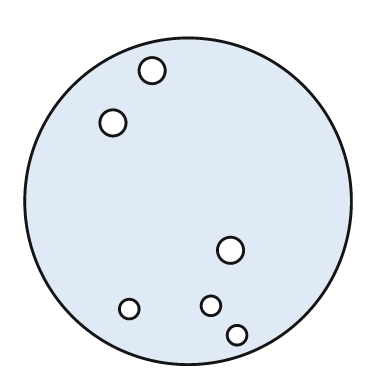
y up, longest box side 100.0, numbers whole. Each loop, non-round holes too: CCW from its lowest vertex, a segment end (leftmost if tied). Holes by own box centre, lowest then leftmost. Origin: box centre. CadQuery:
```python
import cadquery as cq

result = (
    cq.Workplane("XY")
    .moveTo(0.0, 0.0)
    .circle(50.0)
    .moveTo(15.0, -41.0)
    .circle(3.0)
    .moveTo(-18.0, -33.0)
    .circle(3.0)
    .moveTo(7.0, -32.0)
    .circle(3.0)
    .moveTo(13.0, -15.0)
    .circle(4.0)
    .moveTo(-23.0, 24.0)
    .circle(4.0)
    .moveTo(-11.0, 40.0)
    .circle(4.0)
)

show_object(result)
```